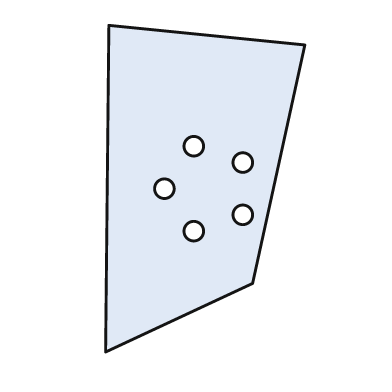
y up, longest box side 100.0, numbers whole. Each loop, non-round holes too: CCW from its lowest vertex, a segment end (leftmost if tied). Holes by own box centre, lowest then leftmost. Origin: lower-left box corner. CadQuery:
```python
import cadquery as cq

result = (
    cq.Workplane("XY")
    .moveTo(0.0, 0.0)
    .lineTo(45.0, 21.0)
    .lineTo(61.0, 94.0)
    .lineTo(1.0, 100.0)
    .close()
    .moveTo(27.0, 37.0)
    .circle(3.0)
    .moveTo(42.0, 42.0)
    .circle(3.0)
    .moveTo(18.0, 50.0)
    .circle(3.0)
    .moveTo(42.0, 58.0)
    .circle(3.0)
    .moveTo(27.0, 63.0)
    .circle(3.0)
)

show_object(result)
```